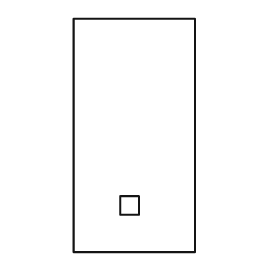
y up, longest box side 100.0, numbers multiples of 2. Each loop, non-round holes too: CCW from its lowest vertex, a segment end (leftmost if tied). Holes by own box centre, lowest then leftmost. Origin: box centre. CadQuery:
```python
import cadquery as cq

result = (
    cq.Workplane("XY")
    .moveTo(-26.0, -50.0)
    .lineTo(26.0, -50.0)
    .lineTo(26.0, 50.0)
    .lineTo(-26.0, 50.0)
    .close()
    .moveTo(-6.0, -34.0)
    .lineTo(2.0, -34.0)
    .lineTo(2.0, -26.0)
    .lineTo(-6.0, -26.0)
    .close()
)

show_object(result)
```